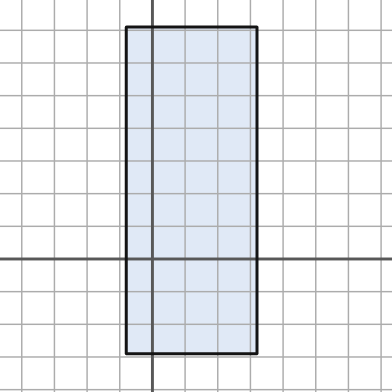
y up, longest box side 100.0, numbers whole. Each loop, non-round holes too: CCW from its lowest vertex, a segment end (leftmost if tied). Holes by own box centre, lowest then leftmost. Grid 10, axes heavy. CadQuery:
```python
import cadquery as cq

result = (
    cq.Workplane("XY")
    .moveTo(-8.0, -29.0)
    .lineTo(32.0, -29.0)
    .lineTo(32.0, 71.0)
    .lineTo(-8.0, 71.0)
    .close()
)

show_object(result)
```